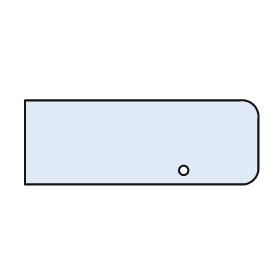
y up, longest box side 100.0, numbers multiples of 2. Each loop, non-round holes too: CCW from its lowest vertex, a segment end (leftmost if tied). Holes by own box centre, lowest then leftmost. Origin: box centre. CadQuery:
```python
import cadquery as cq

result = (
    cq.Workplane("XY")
    .moveTo(-50.0, -18.0)
    .lineTo(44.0, -18.0)
    .threePointArc((48.0, -16.0), (50.0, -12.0))
    .lineTo(50.0, 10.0)
    .threePointArc((48.0, 16.0), (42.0, 18.0))
    .lineTo(-50.0, 18.0)
    .close()
    .moveTo(18.0, -12.0)
    .circle(2.0)
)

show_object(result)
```